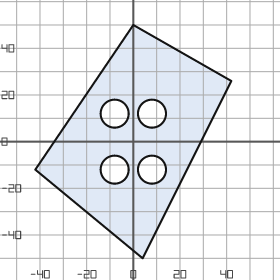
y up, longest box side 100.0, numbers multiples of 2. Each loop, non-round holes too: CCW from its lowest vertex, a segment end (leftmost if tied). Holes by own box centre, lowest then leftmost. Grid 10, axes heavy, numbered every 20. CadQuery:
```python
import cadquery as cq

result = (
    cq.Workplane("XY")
    .moveTo(4.0, -50.0)
    .lineTo(42.0, 26.0)
    .lineTo(0.0, 50.0)
    .lineTo(-42.0, -12.0)
    .close()
    .moveTo(-8.0, -12.0)
    .circle(6.0)
    .moveTo(8.0, -12.0)
    .circle(6.0)
    .moveTo(-8.0, 12.0)
    .circle(6.0)
    .moveTo(8.0, 12.0)
    .circle(6.0)
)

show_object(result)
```